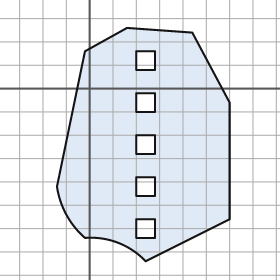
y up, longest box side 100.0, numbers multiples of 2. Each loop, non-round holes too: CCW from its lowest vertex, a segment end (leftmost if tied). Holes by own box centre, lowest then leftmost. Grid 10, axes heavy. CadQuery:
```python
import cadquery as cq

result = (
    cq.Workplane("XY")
    .moveTo(24.0, -74.0)
    .lineTo(60.0, -56.0)
    .lineTo(60.0, -6.0)
    .lineTo(44.0, 24.0)
    .lineTo(16.0, 26.0)
    .lineTo(-2.0, 16.0)
    .lineTo(-14.0, -42.0)
    .threePointArc((-10.0, -54.0), (-2.0, -64.0))
    .threePointArc((12.0, -66.0), (24.0, -74.0))
    .close()
    .moveTo(20.0, -64.0)
    .lineTo(28.0, -64.0)
    .lineTo(28.0, -56.0)
    .lineTo(20.0, -56.0)
    .close()
    .moveTo(20.0, -46.0)
    .lineTo(28.0, -46.0)
    .lineTo(28.0, -38.0)
    .lineTo(20.0, -38.0)
    .close()
    .moveTo(20.0, -28.0)
    .lineTo(28.0, -28.0)
    .lineTo(28.0, -20.0)
    .lineTo(20.0, -20.0)
    .close()
    .moveTo(20.0, -10.0)
    .lineTo(28.0, -10.0)
    .lineTo(28.0, -2.0)
    .lineTo(20.0, -2.0)
    .close()
    .moveTo(20.0, 8.0)
    .lineTo(28.0, 8.0)
    .lineTo(28.0, 16.0)
    .lineTo(20.0, 16.0)
    .close()
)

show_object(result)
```